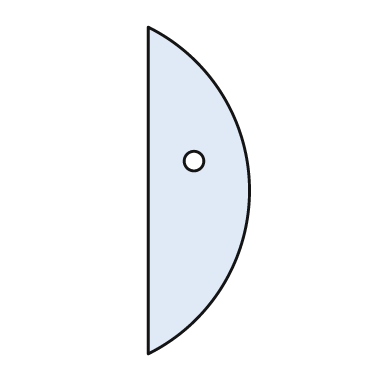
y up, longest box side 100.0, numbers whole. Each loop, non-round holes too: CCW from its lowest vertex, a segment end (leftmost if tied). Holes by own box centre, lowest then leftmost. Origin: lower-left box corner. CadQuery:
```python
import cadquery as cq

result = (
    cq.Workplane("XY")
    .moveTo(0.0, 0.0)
    .threePointArc((31.0, 50.0), (0.0, 100.0))
    .close()
    .moveTo(14.0, 59.0)
    .circle(3.0)
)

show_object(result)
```